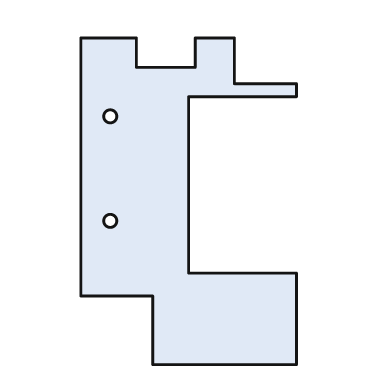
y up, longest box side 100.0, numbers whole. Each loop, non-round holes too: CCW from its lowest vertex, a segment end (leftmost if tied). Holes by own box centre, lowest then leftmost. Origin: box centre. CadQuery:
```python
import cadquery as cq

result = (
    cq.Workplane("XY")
    .moveTo(-11.0, -50.0)
    .lineTo(33.0, -50.0)
    .lineTo(33.0, -22.0)
    .lineTo(0.0, -22.0)
    .lineTo(0.0, 32.0)
    .lineTo(33.0, 32.0)
    .lineTo(33.0, 36.0)
    .lineTo(14.0, 36.0)
    .lineTo(14.0, 50.0)
    .lineTo(2.0, 50.0)
    .lineTo(2.0, 41.0)
    .lineTo(-16.0, 41.0)
    .lineTo(-16.0, 50.0)
    .lineTo(-33.0, 50.0)
    .lineTo(-33.0, -29.0)
    .lineTo(-11.0, -29.0)
    .close()
    .moveTo(-24.0, -6.0)
    .circle(2.0)
    .moveTo(-24.0, 26.0)
    .circle(2.0)
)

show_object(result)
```